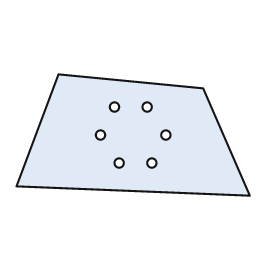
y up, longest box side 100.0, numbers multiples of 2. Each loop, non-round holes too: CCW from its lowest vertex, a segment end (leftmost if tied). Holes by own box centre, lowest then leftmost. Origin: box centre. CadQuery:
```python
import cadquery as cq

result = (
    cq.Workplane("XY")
    .moveTo(50.0, -26.0)
    .lineTo(30.0, 20.0)
    .lineTo(-32.0, 26.0)
    .lineTo(-50.0, -22.0)
    .close()
    .moveTo(-6.0, -12.0)
    .circle(2.0)
    .moveTo(8.0, -12.0)
    .circle(2.0)
    .moveTo(-14.0, 0.0)
    .circle(2.0)
    .moveTo(14.0, 0.0)
    .circle(2.0)
    .moveTo(-8.0, 12.0)
    .circle(2.0)
    .moveTo(6.0, 12.0)
    .circle(2.0)
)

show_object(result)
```